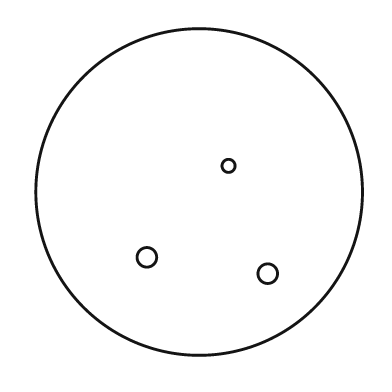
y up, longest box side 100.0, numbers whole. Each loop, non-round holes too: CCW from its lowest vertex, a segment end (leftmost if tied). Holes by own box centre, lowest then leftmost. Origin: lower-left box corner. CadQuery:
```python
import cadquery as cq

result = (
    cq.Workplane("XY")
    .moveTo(50.0, 50.0)
    .circle(50.0)
    .moveTo(71.0, 25.0)
    .circle(3.0)
    .moveTo(34.0, 30.0)
    .circle(3.0)
    .moveTo(59.0, 58.0)
    .circle(2.0)
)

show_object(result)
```